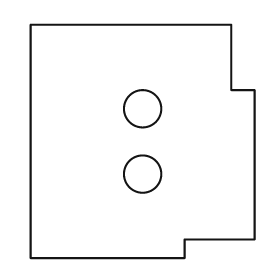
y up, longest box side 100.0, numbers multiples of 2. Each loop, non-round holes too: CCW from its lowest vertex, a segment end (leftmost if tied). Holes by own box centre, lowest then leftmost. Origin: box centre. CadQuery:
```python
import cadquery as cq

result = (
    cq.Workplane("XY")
    .moveTo(-48.0, -50.0)
    .lineTo(18.0, -50.0)
    .lineTo(18.0, -42.0)
    .lineTo(48.0, -42.0)
    .lineTo(48.0, 22.0)
    .lineTo(38.0, 22.0)
    .lineTo(38.0, 50.0)
    .lineTo(-48.0, 50.0)
    .close()
    .moveTo(0.0, -14.0)
    .circle(8.0)
    .moveTo(0.0, 14.0)
    .circle(8.0)
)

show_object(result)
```